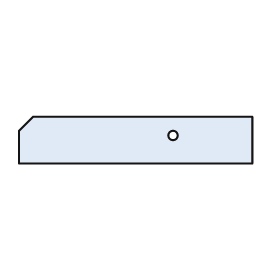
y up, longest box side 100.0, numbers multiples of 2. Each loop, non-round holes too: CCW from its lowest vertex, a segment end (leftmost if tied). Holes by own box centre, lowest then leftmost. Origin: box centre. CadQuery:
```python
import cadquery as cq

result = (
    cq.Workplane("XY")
    .moveTo(-50.0, -10.0)
    .lineTo(50.0, -10.0)
    .lineTo(50.0, 10.0)
    .lineTo(-44.0, 10.0)
    .lineTo(-50.0, 4.0)
    .close()
    .moveTo(16.0, 2.0)
    .circle(2.0)
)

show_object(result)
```